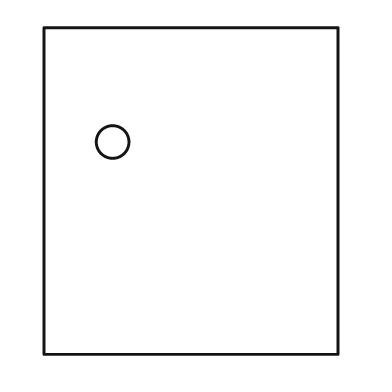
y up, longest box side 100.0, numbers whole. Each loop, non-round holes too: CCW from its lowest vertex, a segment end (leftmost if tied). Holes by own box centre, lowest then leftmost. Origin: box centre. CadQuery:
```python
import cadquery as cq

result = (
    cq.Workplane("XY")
    .moveTo(-45.0, -50.0)
    .lineTo(45.0, -50.0)
    .lineTo(45.0, 50.0)
    .lineTo(-45.0, 50.0)
    .close()
    .moveTo(-24.0, 15.0)
    .circle(5.0)
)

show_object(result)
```